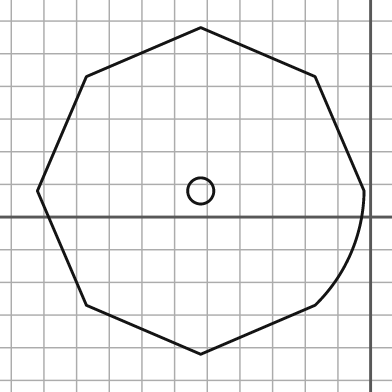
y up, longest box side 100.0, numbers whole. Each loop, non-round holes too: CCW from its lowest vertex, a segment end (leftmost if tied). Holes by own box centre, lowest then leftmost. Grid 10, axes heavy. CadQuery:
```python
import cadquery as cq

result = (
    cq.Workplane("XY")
    .moveTo(-52.0, -42.0)
    .lineTo(-17.0, -27.0)
    .threePointArc((-6.0, -11.0), (-2.0, 8.0))
    .lineTo(-17.0, 43.0)
    .lineTo(-52.0, 58.0)
    .lineTo(-87.0, 43.0)
    .lineTo(-102.0, 8.0)
    .lineTo(-87.0, -27.0)
    .close()
    .moveTo(-52.0, 8.0)
    .circle(4.0)
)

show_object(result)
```